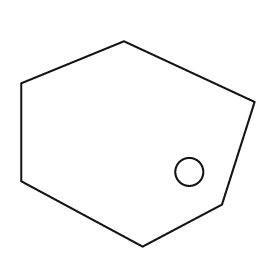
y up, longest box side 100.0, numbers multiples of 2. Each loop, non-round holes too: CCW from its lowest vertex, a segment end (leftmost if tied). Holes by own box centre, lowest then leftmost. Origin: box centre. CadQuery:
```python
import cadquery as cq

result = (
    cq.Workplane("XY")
    .moveTo(2.0, -44.0)
    .lineTo(36.0, -26.0)
    .lineTo(50.0, 18.0)
    .lineTo(-6.0, 44.0)
    .lineTo(-50.0, 26.0)
    .lineTo(-50.0, -16.0)
    .close()
    .moveTo(22.0, -12.0)
    .circle(6.0)
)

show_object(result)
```